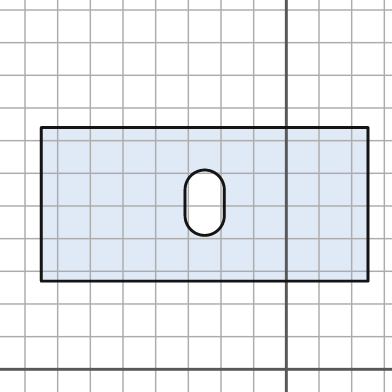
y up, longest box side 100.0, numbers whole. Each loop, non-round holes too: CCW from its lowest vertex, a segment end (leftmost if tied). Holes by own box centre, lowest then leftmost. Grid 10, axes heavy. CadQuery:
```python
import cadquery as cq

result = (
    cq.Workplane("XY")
    .moveTo(-75.0, 27.0)
    .lineTo(25.0, 27.0)
    .lineTo(25.0, 74.0)
    .lineTo(-75.0, 74.0)
    .close()
    .moveTo(-31.0, 47.0)
    .threePointArc((-25.0, 41.0), (-19.0, 47.0))
    .lineTo(-19.0, 55.0)
    .threePointArc((-25.0, 61.0), (-31.0, 55.0))
    .close()
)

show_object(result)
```